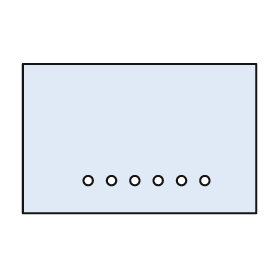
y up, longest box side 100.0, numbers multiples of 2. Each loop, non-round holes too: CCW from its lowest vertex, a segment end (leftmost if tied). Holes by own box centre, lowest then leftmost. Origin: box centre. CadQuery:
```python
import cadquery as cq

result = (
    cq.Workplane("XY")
    .moveTo(-50.0, -32.0)
    .lineTo(50.0, -32.0)
    .lineTo(50.0, 32.0)
    .lineTo(-50.0, 32.0)
    .close()
    .moveTo(-22.0, -18.0)
    .circle(2.0)
    .moveTo(-12.0, -18.0)
    .circle(2.0)
    .moveTo(-2.0, -18.0)
    .circle(2.0)
    .moveTo(8.0, -18.0)
    .circle(2.0)
    .moveTo(18.0, -18.0)
    .circle(2.0)
    .moveTo(28.0, -18.0)
    .circle(2.0)
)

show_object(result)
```